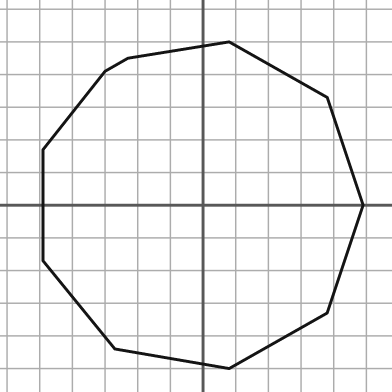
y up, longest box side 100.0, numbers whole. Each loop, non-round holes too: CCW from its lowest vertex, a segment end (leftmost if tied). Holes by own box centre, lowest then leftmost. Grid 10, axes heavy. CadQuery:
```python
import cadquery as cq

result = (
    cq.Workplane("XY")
    .moveTo(8.0, -50.0)
    .lineTo(38.0, -33.0)
    .lineTo(49.0, 0.0)
    .lineTo(38.0, 33.0)
    .lineTo(8.0, 50.0)
    .lineTo(-23.0, 45.0)
    .lineTo(-30.0, 41.0)
    .lineTo(-49.0, 17.0)
    .lineTo(-49.0, -17.0)
    .lineTo(-27.0, -44.0)
    .close()
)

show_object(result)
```